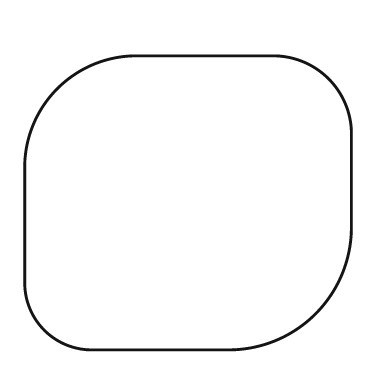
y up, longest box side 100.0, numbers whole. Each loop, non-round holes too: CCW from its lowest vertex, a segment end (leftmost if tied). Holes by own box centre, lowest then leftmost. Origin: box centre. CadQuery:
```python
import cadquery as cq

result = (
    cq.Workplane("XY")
    .moveTo(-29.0, -45.0)
    .lineTo(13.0, -45.0)
    .threePointArc((39.0, -34.0), (50.0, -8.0))
    .lineTo(50.0, 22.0)
    .threePointArc((43.0, 38.0), (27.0, 45.0))
    .lineTo(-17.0, 45.0)
    .threePointArc((-40.0, 35.0), (-50.0, 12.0))
    .lineTo(-50.0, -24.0)
    .threePointArc((-44.0, -39.0), (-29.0, -45.0))
    .close()
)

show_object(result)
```